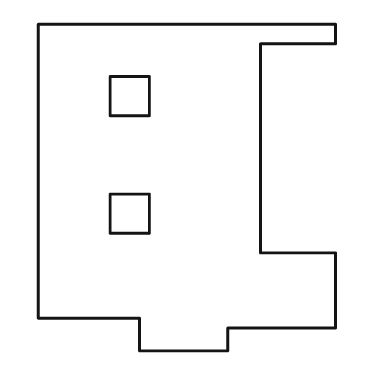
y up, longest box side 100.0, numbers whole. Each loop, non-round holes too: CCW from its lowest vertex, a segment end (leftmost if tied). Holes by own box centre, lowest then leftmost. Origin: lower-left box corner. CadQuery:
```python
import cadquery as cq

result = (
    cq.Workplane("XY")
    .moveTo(31.0, 0.0)
    .lineTo(58.0, 0.0)
    .lineTo(58.0, 7.0)
    .lineTo(91.0, 7.0)
    .lineTo(91.0, 30.0)
    .lineTo(68.0, 30.0)
    .lineTo(68.0, 94.0)
    .lineTo(91.0, 94.0)
    .lineTo(91.0, 100.0)
    .lineTo(0.0, 100.0)
    .lineTo(0.0, 10.0)
    .lineTo(31.0, 10.0)
    .close()
    .moveTo(22.0, 36.0)
    .lineTo(34.0, 36.0)
    .lineTo(34.0, 48.0)
    .lineTo(22.0, 48.0)
    .close()
    .moveTo(22.0, 72.0)
    .lineTo(34.0, 72.0)
    .lineTo(34.0, 84.0)
    .lineTo(22.0, 84.0)
    .close()
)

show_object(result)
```